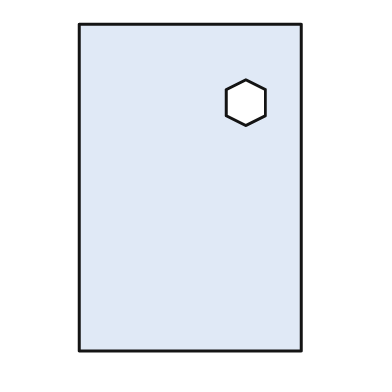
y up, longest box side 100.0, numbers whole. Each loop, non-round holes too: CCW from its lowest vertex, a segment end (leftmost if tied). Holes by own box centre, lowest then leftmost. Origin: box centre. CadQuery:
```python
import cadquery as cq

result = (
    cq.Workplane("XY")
    .moveTo(-34.0, -50.0)
    .lineTo(34.0, -50.0)
    .lineTo(34.0, 50.0)
    .lineTo(-34.0, 50.0)
    .close()
    .moveTo(17.0, 19.0)
    .lineTo(23.0, 22.0)
    .lineTo(23.0, 30.0)
    .lineTo(17.0, 33.0)
    .lineTo(11.0, 30.0)
    .lineTo(11.0, 22.0)
    .close()
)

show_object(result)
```